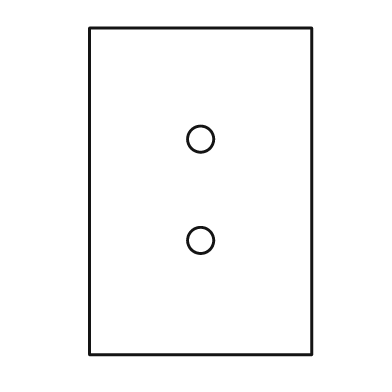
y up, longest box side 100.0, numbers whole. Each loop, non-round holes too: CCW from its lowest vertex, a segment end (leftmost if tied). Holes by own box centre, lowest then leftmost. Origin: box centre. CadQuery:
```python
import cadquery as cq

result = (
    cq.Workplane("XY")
    .moveTo(-34.0, -50.0)
    .lineTo(34.0, -50.0)
    .lineTo(34.0, 50.0)
    .lineTo(-34.0, 50.0)
    .close()
    .moveTo(0.0, -15.0)
    .circle(4.0)
    .moveTo(0.0, 16.0)
    .circle(4.0)
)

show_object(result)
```